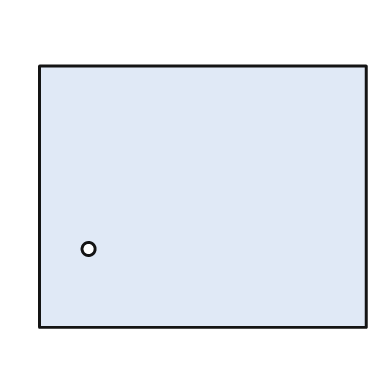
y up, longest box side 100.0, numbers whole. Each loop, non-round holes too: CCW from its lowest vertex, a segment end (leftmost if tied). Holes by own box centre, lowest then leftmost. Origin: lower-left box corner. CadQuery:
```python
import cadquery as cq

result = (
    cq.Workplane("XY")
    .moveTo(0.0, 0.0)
    .lineTo(100.0, 0.0)
    .lineTo(100.0, 80.0)
    .lineTo(0.0, 80.0)
    .close()
    .moveTo(15.0, 24.0)
    .circle(2.0)
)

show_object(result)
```